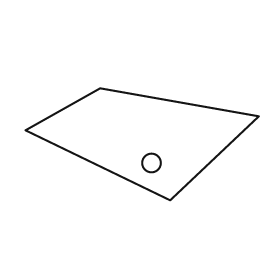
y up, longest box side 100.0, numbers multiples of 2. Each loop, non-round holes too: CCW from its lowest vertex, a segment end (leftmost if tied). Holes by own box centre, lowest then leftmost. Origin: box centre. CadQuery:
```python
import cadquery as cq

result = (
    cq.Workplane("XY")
    .moveTo(12.0, -24.0)
    .lineTo(50.0, 12.0)
    .lineTo(-18.0, 24.0)
    .lineTo(-50.0, 6.0)
    .close()
    .moveTo(4.0, -8.0)
    .circle(4.0)
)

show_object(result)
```